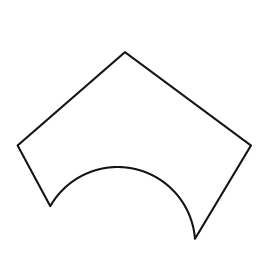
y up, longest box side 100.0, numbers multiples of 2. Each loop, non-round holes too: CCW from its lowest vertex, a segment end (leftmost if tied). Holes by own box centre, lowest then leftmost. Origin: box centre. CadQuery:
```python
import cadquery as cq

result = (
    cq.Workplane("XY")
    .moveTo(26.0, -40.0)
    .lineTo(50.0, 0.0)
    .lineTo(-4.0, 40.0)
    .lineTo(-50.0, 0.0)
    .lineTo(-36.0, -26.0)
    .threePointArc((0.0, -10.0), (26.0, -40.0))
    .close()
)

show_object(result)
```